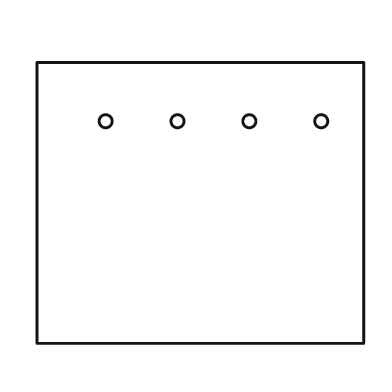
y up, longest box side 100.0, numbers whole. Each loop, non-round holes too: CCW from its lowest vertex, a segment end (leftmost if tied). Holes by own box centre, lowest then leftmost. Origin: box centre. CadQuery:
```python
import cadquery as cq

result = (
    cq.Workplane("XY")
    .moveTo(-50.0, -43.0)
    .lineTo(50.0, -43.0)
    .lineTo(50.0, 43.0)
    .lineTo(-50.0, 43.0)
    .close()
    .moveTo(-29.0, 25.0)
    .circle(2.0)
    .moveTo(-7.0, 25.0)
    .circle(2.0)
    .moveTo(15.0, 25.0)
    .circle(2.0)
    .moveTo(37.0, 25.0)
    .circle(2.0)
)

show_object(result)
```